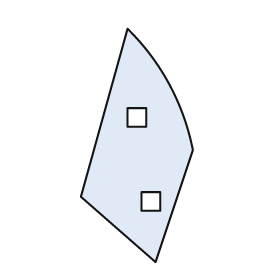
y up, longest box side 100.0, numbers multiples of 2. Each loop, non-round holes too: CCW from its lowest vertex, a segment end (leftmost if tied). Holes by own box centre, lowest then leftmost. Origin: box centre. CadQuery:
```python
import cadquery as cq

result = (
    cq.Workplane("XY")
    .moveTo(8.0, -50.0)
    .lineTo(24.0, -2.0)
    .threePointArc((14.0, 26.0), (-4.0, 50.0))
    .lineTo(-24.0, -22.0)
    .close()
    .moveTo(2.0, -28.0)
    .lineTo(10.0, -28.0)
    .lineTo(10.0, -20.0)
    .lineTo(2.0, -20.0)
    .close()
    .moveTo(-4.0, 8.0)
    .lineTo(4.0, 8.0)
    .lineTo(4.0, 16.0)
    .lineTo(-4.0, 16.0)
    .close()
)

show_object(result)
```